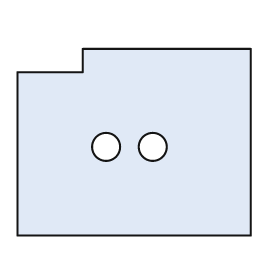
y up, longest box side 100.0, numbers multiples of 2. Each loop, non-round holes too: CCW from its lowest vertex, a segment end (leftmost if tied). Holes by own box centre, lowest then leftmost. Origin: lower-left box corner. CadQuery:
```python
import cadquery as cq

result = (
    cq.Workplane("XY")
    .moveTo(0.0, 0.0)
    .lineTo(100.0, 0.0)
    .lineTo(100.0, 80.0)
    .lineTo(28.0, 80.0)
    .lineTo(28.0, 70.0)
    .lineTo(0.0, 70.0)
    .close()
    .moveTo(38.0, 38.0)
    .circle(6.0)
    .moveTo(58.0, 38.0)
    .circle(6.0)
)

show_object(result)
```